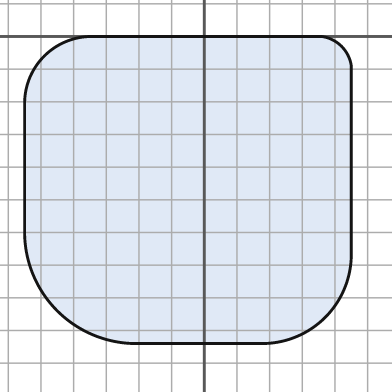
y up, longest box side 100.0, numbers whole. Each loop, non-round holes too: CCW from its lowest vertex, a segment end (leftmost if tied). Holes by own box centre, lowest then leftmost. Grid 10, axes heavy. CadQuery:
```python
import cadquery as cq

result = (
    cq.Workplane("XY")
    .moveTo(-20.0, -94.0)
    .lineTo(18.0, -94.0)
    .threePointArc((37.0, -86.0), (45.0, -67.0))
    .lineTo(45.0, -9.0)
    .threePointArc((42.0, -3.0), (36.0, 0.0))
    .lineTo(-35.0, 0.0)
    .threePointArc((-49.0, -6.0), (-55.0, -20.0))
    .lineTo(-55.0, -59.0)
    .threePointArc((-45.0, -84.0), (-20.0, -94.0))
    .close()
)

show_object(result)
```